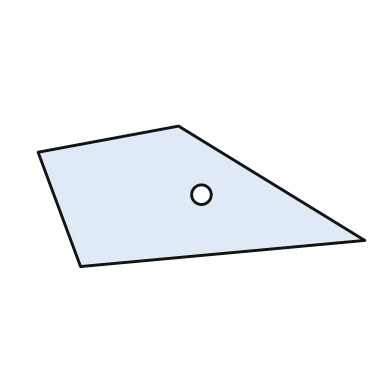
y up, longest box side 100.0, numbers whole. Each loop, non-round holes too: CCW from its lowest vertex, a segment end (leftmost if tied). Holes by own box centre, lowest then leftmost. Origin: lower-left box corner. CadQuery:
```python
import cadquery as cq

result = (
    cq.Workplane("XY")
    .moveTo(13.0, 0.0)
    .lineTo(100.0, 8.0)
    .lineTo(43.0, 43.0)
    .lineTo(0.0, 35.0)
    .close()
    .moveTo(50.0, 22.0)
    .circle(3.0)
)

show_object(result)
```